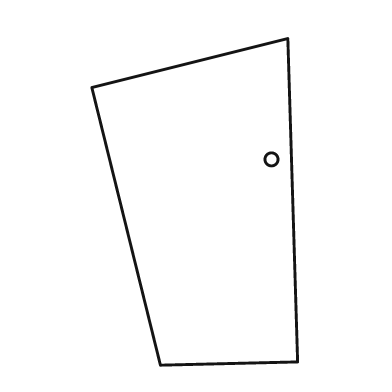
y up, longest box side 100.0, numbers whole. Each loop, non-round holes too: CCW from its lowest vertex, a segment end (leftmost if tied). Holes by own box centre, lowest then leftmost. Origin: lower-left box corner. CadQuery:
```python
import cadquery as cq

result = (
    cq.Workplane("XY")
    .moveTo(21.0, 0.0)
    .lineTo(63.0, 1.0)
    .lineTo(60.0, 100.0)
    .lineTo(0.0, 85.0)
    .close()
    .moveTo(55.0, 63.0)
    .circle(2.0)
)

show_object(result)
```